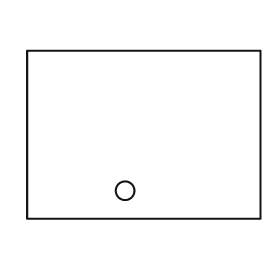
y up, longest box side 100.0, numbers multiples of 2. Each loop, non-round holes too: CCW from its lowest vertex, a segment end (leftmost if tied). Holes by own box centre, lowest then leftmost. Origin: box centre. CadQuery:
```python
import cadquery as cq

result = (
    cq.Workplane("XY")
    .moveTo(-50.0, -36.0)
    .lineTo(50.0, -36.0)
    .lineTo(50.0, 36.0)
    .lineTo(-50.0, 36.0)
    .close()
    .moveTo(-8.0, -24.0)
    .circle(4.0)
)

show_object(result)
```